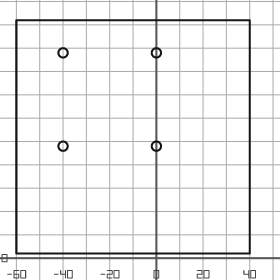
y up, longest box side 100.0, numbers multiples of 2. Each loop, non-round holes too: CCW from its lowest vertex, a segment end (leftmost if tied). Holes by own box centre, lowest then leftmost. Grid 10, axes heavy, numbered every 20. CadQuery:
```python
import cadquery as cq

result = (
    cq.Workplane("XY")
    .moveTo(-60.0, 2.0)
    .lineTo(40.0, 2.0)
    .lineTo(40.0, 102.0)
    .lineTo(-60.0, 102.0)
    .close()
    .moveTo(-40.0, 48.0)
    .circle(2.0)
    .moveTo(0.0, 48.0)
    .circle(2.0)
    .moveTo(-40.0, 88.0)
    .circle(2.0)
    .moveTo(0.0, 88.0)
    .circle(2.0)
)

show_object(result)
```